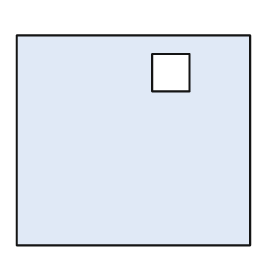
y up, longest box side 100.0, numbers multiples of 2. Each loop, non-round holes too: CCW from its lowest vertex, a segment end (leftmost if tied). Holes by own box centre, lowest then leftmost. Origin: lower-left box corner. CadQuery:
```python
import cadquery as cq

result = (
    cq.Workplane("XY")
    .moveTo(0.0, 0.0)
    .lineTo(100.0, 0.0)
    .lineTo(100.0, 90.0)
    .lineTo(0.0, 90.0)
    .close()
    .moveTo(58.0, 66.0)
    .lineTo(74.0, 66.0)
    .lineTo(74.0, 82.0)
    .lineTo(58.0, 82.0)
    .close()
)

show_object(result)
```